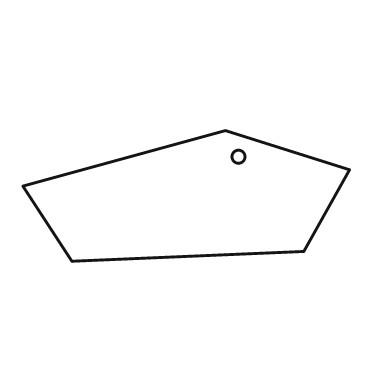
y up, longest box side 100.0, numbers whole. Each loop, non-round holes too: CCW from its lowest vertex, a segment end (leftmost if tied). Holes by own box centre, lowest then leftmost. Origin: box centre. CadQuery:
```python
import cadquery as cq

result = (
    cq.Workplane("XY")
    .moveTo(-35.0, -20.0)
    .lineTo(36.0, -17.0)
    .lineTo(50.0, 8.0)
    .lineTo(12.0, 20.0)
    .lineTo(-50.0, 3.0)
    .close()
    .moveTo(16.0, 12.0)
    .circle(2.0)
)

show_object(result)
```